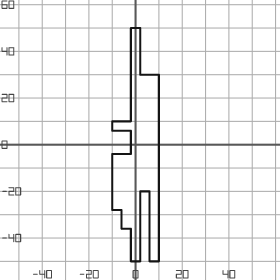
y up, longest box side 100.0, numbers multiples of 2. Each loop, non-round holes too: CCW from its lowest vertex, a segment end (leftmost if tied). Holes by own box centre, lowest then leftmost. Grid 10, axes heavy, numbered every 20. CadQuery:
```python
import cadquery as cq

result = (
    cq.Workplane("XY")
    .moveTo(-2.0, -50.0)
    .lineTo(2.0, -50.0)
    .lineTo(2.0, -20.0)
    .lineTo(6.0, -20.0)
    .lineTo(6.0, -50.0)
    .lineTo(10.0, -50.0)
    .lineTo(10.0, 30.0)
    .lineTo(2.0, 30.0)
    .lineTo(2.0, 50.0)
    .lineTo(-2.0, 50.0)
    .lineTo(-2.0, 10.0)
    .lineTo(-10.0, 10.0)
    .lineTo(-10.0, 6.0)
    .lineTo(-2.0, 6.0)
    .lineTo(-2.0, -4.0)
    .lineTo(-10.0, -4.0)
    .lineTo(-10.0, -28.0)
    .lineTo(-6.0, -28.0)
    .lineTo(-6.0, -36.0)
    .lineTo(-2.0, -36.0)
    .close()
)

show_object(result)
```